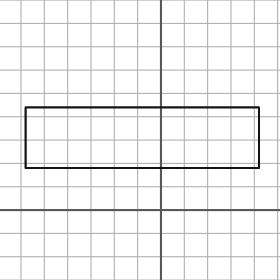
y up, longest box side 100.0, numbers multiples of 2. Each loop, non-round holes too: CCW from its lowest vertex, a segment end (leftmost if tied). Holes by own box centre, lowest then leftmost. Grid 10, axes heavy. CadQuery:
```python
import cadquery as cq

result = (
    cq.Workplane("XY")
    .moveTo(-58.0, 18.0)
    .lineTo(42.0, 18.0)
    .lineTo(42.0, 44.0)
    .lineTo(-58.0, 44.0)
    .close()
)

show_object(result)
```